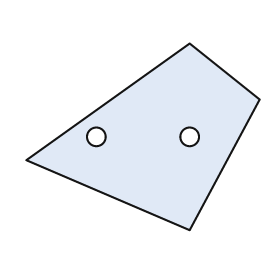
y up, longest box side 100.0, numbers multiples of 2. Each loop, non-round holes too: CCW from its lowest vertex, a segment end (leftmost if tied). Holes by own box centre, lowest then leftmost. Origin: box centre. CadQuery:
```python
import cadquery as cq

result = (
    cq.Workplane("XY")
    .moveTo(20.0, -40.0)
    .lineTo(50.0, 16.0)
    .lineTo(20.0, 40.0)
    .lineTo(-50.0, -10.0)
    .close()
    .moveTo(-20.0, 0.0)
    .circle(4.0)
    .moveTo(20.0, 0.0)
    .circle(4.0)
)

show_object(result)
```